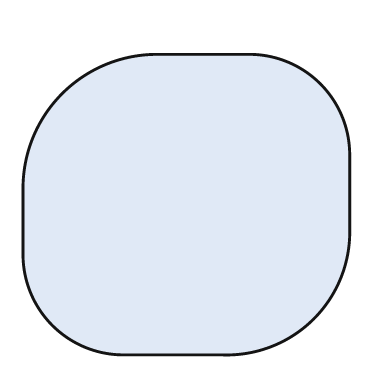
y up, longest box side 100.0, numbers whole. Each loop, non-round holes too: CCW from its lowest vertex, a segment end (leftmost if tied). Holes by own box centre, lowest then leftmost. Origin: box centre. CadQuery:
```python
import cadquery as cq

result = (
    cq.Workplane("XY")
    .moveTo(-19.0, -46.0)
    .lineTo(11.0, -46.0)
    .threePointArc((39.0, -35.0), (50.0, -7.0))
    .lineTo(50.0, 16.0)
    .threePointArc((41.0, 37.0), (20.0, 46.0))
    .lineTo(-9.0, 46.0)
    .threePointArc((-38.0, 34.0), (-50.0, 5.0))
    .lineTo(-50.0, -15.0)
    .threePointArc((-41.0, -37.0), (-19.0, -46.0))
    .close()
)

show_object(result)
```